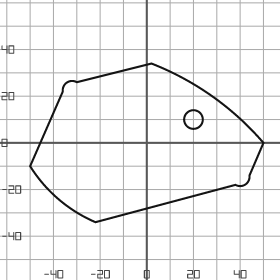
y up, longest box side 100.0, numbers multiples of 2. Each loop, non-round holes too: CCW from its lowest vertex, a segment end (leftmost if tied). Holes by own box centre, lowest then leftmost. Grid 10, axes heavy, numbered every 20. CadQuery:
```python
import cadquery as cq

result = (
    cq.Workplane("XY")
    .moveTo(-22.0, -34.0)
    .lineTo(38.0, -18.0)
    .threePointArc((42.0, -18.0), (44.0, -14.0))
    .lineTo(50.0, 0.0)
    .threePointArc((28.0, 20.0), (2.0, 34.0))
    .lineTo(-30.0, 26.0)
    .threePointArc((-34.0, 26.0), (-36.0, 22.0))
    .lineTo(-50.0, -10.0)
    .threePointArc((-38.0, -24.0), (-22.0, -34.0))
    .close()
    .moveTo(20.0, 10.0)
    .circle(4.0)
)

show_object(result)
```